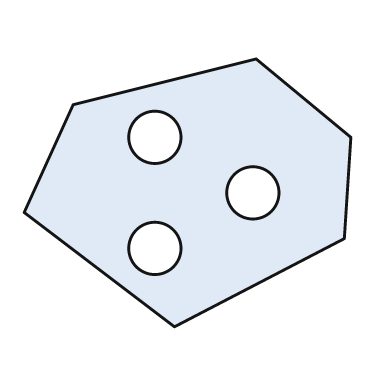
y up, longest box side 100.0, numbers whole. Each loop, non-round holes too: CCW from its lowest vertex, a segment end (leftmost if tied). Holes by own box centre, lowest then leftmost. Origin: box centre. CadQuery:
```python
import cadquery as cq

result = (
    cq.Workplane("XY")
    .moveTo(-4.0, -41.0)
    .lineTo(48.0, -14.0)
    .lineTo(50.0, 17.0)
    .lineTo(21.0, 41.0)
    .lineTo(-35.0, 27.0)
    .lineTo(-50.0, -6.0)
    .close()
    .moveTo(-10.0, -17.0)
    .circle(8.0)
    .moveTo(20.0, 0.0)
    .circle(8.0)
    .moveTo(-10.0, 17.0)
    .circle(8.0)
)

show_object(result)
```